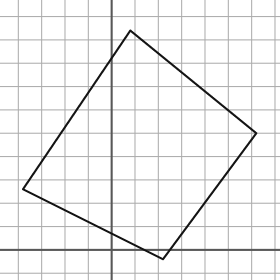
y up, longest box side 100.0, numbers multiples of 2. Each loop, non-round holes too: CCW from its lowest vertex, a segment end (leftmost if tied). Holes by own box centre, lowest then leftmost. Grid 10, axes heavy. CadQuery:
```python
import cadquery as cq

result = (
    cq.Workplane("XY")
    .moveTo(22.0, -4.0)
    .lineTo(62.0, 50.0)
    .lineTo(8.0, 94.0)
    .lineTo(-38.0, 26.0)
    .close()
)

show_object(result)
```